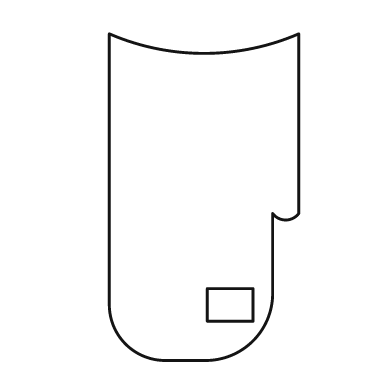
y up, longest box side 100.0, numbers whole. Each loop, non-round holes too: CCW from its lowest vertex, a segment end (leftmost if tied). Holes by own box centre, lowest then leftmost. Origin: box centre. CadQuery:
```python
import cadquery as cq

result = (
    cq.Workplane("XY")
    .moveTo(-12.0, -50.0)
    .lineTo(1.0, -50.0)
    .threePointArc((15.0, -44.0), (21.0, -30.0))
    .lineTo(21.0, -5.0)
    .threePointArc((25.0, -7.0), (29.0, -5.0))
    .lineTo(29.0, 50.0)
    .threePointArc((0.0, 44.0), (-29.0, 50.0))
    .lineTo(-29.0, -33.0)
    .threePointArc((-24.0, -45.0), (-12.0, -50.0))
    .close()
    .moveTo(1.0, -38.0)
    .lineTo(15.0, -38.0)
    .lineTo(15.0, -28.0)
    .lineTo(1.0, -28.0)
    .close()
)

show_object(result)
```